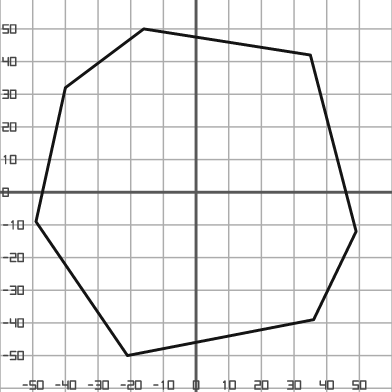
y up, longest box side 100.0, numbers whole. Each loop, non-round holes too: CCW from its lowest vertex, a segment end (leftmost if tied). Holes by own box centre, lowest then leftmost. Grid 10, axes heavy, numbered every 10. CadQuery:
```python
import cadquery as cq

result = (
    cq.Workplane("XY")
    .moveTo(-21.0, -50.0)
    .lineTo(36.0, -39.0)
    .lineTo(49.0, -12.0)
    .lineTo(35.0, 42.0)
    .lineTo(-16.0, 50.0)
    .lineTo(-40.0, 32.0)
    .lineTo(-49.0, -9.0)
    .close()
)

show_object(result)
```